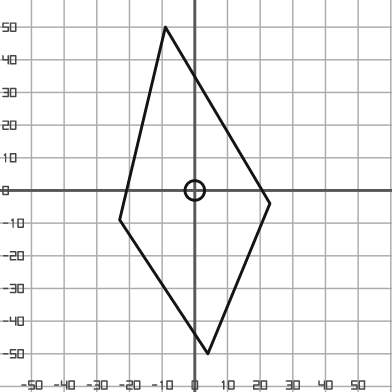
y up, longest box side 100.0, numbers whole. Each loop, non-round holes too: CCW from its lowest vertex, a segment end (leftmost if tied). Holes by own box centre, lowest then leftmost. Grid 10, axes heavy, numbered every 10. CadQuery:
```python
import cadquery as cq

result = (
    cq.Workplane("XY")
    .moveTo(4.0, -50.0)
    .lineTo(23.0, -4.0)
    .lineTo(-9.0, 50.0)
    .lineTo(-23.0, -9.0)
    .close()
    .moveTo(0.0, 0.0)
    .circle(3.0)
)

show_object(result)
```